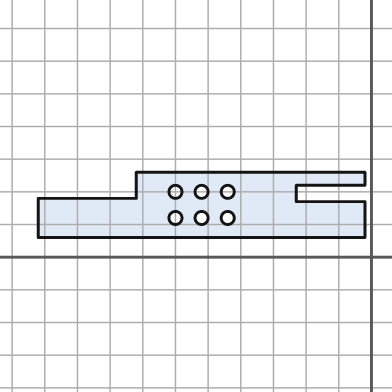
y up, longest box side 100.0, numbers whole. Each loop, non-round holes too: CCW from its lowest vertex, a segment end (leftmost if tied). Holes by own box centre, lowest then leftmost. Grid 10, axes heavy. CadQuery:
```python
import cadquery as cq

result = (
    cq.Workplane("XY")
    .moveTo(-102.0, 6.0)
    .lineTo(-2.0, 6.0)
    .lineTo(-2.0, 17.0)
    .lineTo(-23.0, 17.0)
    .lineTo(-23.0, 22.0)
    .lineTo(-2.0, 22.0)
    .lineTo(-2.0, 26.0)
    .lineTo(-72.0, 26.0)
    .lineTo(-72.0, 18.0)
    .lineTo(-102.0, 18.0)
    .close()
    .moveTo(-60.0, 12.0)
    .circle(2.0)
    .moveTo(-52.0, 12.0)
    .circle(2.0)
    .moveTo(-44.0, 12.0)
    .circle(2.0)
    .moveTo(-60.0, 20.0)
    .circle(2.0)
    .moveTo(-52.0, 20.0)
    .circle(2.0)
    .moveTo(-44.0, 20.0)
    .circle(2.0)
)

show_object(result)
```